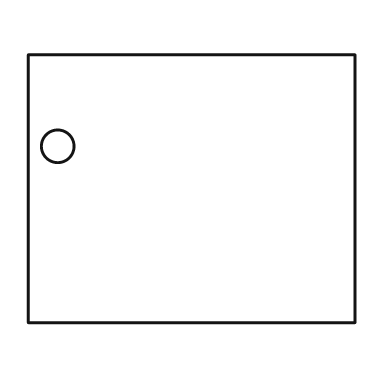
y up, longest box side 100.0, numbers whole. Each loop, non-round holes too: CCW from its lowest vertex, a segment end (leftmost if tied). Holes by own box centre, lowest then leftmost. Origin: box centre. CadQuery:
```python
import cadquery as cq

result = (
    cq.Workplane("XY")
    .moveTo(-50.0, -41.0)
    .lineTo(50.0, -41.0)
    .lineTo(50.0, 41.0)
    .lineTo(-50.0, 41.0)
    .close()
    .moveTo(-41.0, 13.0)
    .circle(5.0)
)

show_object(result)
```